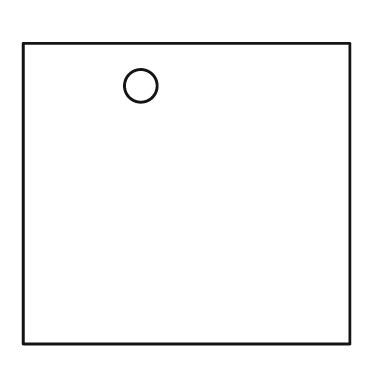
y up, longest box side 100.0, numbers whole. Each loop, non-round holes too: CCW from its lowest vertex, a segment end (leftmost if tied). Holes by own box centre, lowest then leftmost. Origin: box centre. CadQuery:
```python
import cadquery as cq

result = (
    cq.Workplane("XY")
    .moveTo(-50.0, -46.0)
    .lineTo(50.0, -46.0)
    .lineTo(50.0, 46.0)
    .lineTo(-50.0, 46.0)
    .close()
    .moveTo(-14.0, 33.0)
    .circle(5.0)
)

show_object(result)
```